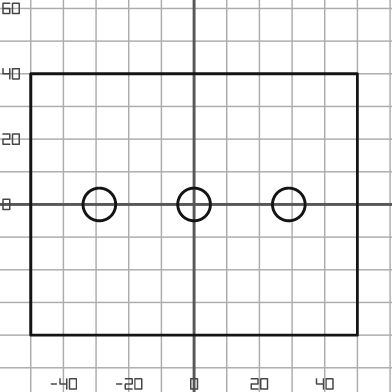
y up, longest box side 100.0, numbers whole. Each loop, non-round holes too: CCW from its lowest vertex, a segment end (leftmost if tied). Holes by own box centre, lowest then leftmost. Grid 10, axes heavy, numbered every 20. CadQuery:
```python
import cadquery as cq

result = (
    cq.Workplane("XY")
    .moveTo(-50.0, -40.0)
    .lineTo(50.0, -40.0)
    .lineTo(50.0, 40.0)
    .lineTo(-50.0, 40.0)
    .close()
    .moveTo(-29.0, 0.0)
    .circle(5.0)
    .moveTo(0.0, 0.0)
    .circle(5.0)
    .moveTo(29.0, 0.0)
    .circle(5.0)
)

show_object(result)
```